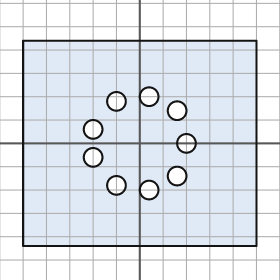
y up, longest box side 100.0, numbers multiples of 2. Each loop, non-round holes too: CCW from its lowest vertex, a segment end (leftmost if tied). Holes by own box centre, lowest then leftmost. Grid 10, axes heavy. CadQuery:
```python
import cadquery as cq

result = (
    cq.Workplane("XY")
    .moveTo(-50.0, -44.0)
    .lineTo(50.0, -44.0)
    .lineTo(50.0, 44.0)
    .lineTo(-50.0, 44.0)
    .close()
    .moveTo(4.0, -20.0)
    .circle(4.0)
    .moveTo(-10.0, -18.0)
    .circle(4.0)
    .moveTo(16.0, -14.0)
    .circle(4.0)
    .moveTo(-20.0, -6.0)
    .circle(4.0)
    .moveTo(20.0, 0.0)
    .circle(4.0)
    .moveTo(-20.0, 6.0)
    .circle(4.0)
    .moveTo(16.0, 14.0)
    .circle(4.0)
    .moveTo(-10.0, 18.0)
    .circle(4.0)
    .moveTo(4.0, 20.0)
    .circle(4.0)
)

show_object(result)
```